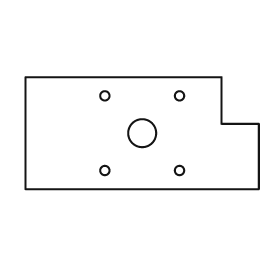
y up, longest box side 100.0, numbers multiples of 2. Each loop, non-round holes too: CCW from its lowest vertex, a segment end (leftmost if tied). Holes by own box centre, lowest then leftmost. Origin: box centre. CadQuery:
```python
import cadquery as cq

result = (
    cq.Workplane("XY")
    .moveTo(-50.0, -24.0)
    .lineTo(50.0, -24.0)
    .lineTo(50.0, 4.0)
    .lineTo(34.0, 4.0)
    .lineTo(34.0, 24.0)
    .lineTo(-50.0, 24.0)
    .close()
    .moveTo(-16.0, -16.0)
    .circle(2.0)
    .moveTo(16.0, -16.0)
    .circle(2.0)
    .moveTo(0.0, 0.0)
    .circle(6.0)
    .moveTo(-16.0, 16.0)
    .circle(2.0)
    .moveTo(16.0, 16.0)
    .circle(2.0)
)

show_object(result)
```